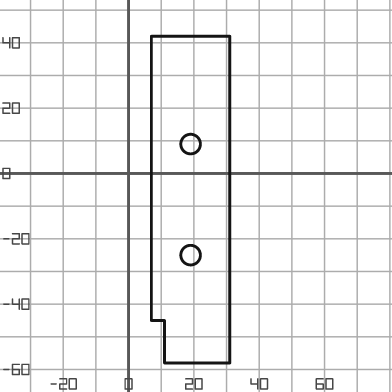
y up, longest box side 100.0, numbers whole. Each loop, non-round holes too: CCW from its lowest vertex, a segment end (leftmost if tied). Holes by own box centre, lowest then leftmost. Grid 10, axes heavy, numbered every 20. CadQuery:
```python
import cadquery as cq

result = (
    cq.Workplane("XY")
    .moveTo(11.0, -58.0)
    .lineTo(31.0, -58.0)
    .lineTo(31.0, 42.0)
    .lineTo(7.0, 42.0)
    .lineTo(7.0, -45.0)
    .lineTo(11.0, -45.0)
    .close()
    .moveTo(19.0, -25.0)
    .circle(3.0)
    .moveTo(19.0, 9.0)
    .circle(3.0)
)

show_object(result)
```